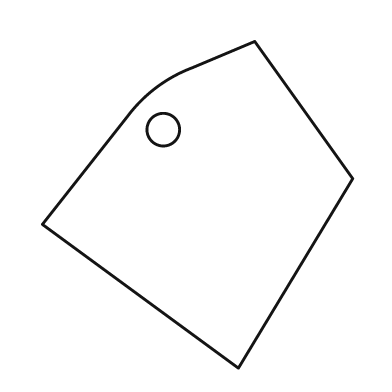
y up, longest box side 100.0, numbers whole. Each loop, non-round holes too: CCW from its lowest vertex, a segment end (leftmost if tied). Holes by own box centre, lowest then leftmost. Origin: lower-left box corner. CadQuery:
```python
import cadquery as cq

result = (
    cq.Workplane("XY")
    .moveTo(60.0, 0.0)
    .lineTo(95.0, 58.0)
    .lineTo(65.0, 100.0)
    .lineTo(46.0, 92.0)
    .threePointArc((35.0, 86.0), (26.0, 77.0))
    .lineTo(0.0, 44.0)
    .close()
    .moveTo(37.0, 73.0)
    .circle(5.0)
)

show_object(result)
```